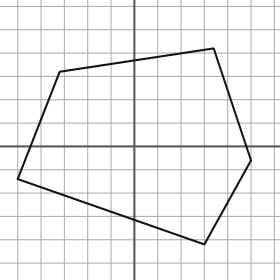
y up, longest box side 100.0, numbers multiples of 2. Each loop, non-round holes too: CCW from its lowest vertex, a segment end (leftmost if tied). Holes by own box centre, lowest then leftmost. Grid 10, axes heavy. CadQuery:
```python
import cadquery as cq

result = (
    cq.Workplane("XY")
    .moveTo(30.0, -42.0)
    .lineTo(50.0, -6.0)
    .lineTo(34.0, 42.0)
    .lineTo(-32.0, 32.0)
    .lineTo(-50.0, -14.0)
    .close()
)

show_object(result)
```